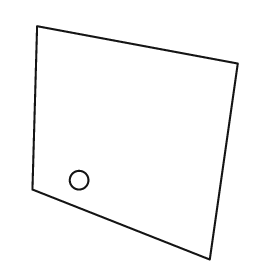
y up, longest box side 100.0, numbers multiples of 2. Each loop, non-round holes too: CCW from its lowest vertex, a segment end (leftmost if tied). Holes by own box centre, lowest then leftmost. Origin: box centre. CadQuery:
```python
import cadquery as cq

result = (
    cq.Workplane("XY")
    .moveTo(32.0, -50.0)
    .lineTo(44.0, 34.0)
    .lineTo(-42.0, 50.0)
    .lineTo(-44.0, -20.0)
    .close()
    .moveTo(-24.0, -16.0)
    .circle(4.0)
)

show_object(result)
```